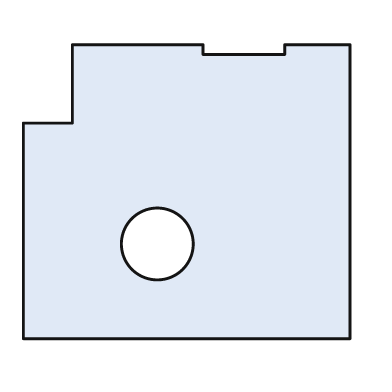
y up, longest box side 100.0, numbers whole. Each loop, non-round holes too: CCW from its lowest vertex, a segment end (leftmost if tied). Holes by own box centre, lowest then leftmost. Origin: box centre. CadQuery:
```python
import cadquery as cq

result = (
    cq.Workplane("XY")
    .moveTo(-50.0, -45.0)
    .lineTo(50.0, -45.0)
    .lineTo(50.0, 45.0)
    .lineTo(30.0, 45.0)
    .lineTo(30.0, 42.0)
    .lineTo(5.0, 42.0)
    .lineTo(5.0, 45.0)
    .lineTo(-35.0, 45.0)
    .lineTo(-35.0, 21.0)
    .lineTo(-50.0, 21.0)
    .close()
    .moveTo(-9.0, -16.0)
    .circle(11.0)
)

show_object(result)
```